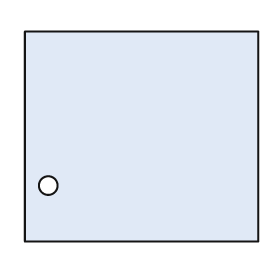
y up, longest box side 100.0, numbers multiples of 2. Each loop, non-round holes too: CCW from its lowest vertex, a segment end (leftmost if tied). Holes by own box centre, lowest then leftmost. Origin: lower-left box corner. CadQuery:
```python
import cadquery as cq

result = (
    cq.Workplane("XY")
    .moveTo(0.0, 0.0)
    .lineTo(100.0, 0.0)
    .lineTo(100.0, 90.0)
    .lineTo(0.0, 90.0)
    .close()
    .moveTo(10.0, 24.0)
    .circle(4.0)
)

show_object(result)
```